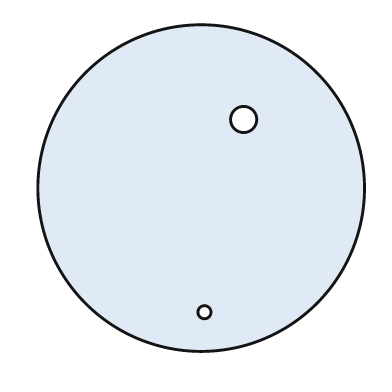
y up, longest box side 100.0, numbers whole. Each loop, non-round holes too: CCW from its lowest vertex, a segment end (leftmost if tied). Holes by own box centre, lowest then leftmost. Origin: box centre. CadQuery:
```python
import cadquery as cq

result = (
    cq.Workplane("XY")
    .moveTo(0.0, 0.0)
    .circle(50.0)
    .moveTo(1.0, -38.0)
    .circle(2.0)
    .moveTo(13.0, 21.0)
    .circle(4.0)
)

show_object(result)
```